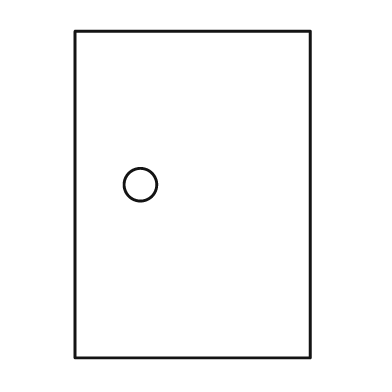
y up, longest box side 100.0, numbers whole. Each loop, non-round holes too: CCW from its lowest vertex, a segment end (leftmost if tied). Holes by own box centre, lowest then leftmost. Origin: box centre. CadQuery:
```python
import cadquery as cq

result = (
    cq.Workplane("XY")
    .moveTo(-36.0, -50.0)
    .lineTo(36.0, -50.0)
    .lineTo(36.0, 50.0)
    .lineTo(-36.0, 50.0)
    .close()
    .moveTo(-16.0, 3.0)
    .circle(5.0)
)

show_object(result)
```